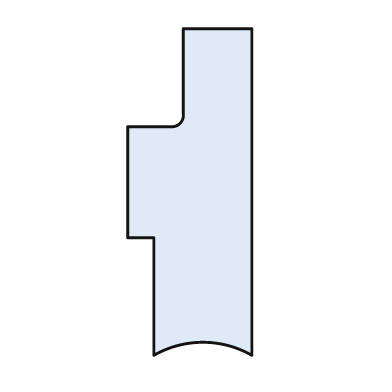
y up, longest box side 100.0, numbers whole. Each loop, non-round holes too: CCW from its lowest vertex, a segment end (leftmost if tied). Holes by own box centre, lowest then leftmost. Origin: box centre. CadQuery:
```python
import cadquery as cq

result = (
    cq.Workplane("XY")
    .moveTo(-11.0, -50.0)
    .threePointArc((4.0, -46.0), (19.0, -50.0))
    .lineTo(19.0, 50.0)
    .lineTo(-2.0, 50.0)
    .lineTo(-2.0, 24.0)
    .threePointArc((-3.0, 21.0), (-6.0, 20.0))
    .lineTo(-19.0, 20.0)
    .lineTo(-19.0, -14.0)
    .lineTo(-11.0, -14.0)
    .close()
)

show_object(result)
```